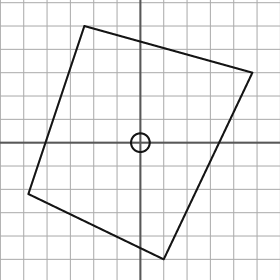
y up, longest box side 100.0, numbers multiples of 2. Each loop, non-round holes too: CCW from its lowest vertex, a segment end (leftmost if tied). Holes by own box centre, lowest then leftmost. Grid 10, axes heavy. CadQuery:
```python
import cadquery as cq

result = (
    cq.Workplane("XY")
    .moveTo(10.0, -50.0)
    .lineTo(48.0, 30.0)
    .lineTo(-24.0, 50.0)
    .lineTo(-48.0, -22.0)
    .close()
    .moveTo(0.0, 0.0)
    .circle(4.0)
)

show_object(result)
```